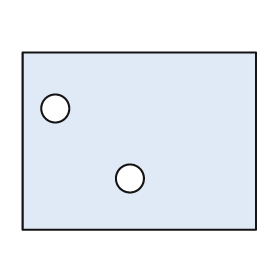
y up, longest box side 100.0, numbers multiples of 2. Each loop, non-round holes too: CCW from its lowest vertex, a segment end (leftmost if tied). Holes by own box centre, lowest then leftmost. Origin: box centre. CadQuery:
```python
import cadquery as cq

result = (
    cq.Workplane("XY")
    .moveTo(-50.0, -38.0)
    .lineTo(50.0, -38.0)
    .lineTo(50.0, 38.0)
    .lineTo(-50.0, 38.0)
    .close()
    .moveTo(-4.0, -16.0)
    .circle(6.0)
    .moveTo(-36.0, 14.0)
    .circle(6.0)
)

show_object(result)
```